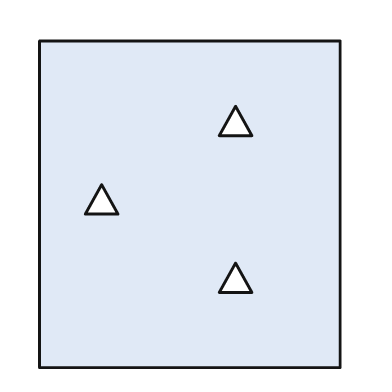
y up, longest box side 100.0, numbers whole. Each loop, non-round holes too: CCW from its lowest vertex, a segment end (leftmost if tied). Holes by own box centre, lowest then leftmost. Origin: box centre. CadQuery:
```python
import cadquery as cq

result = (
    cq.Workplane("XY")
    .moveTo(-46.0, -50.0)
    .lineTo(46.0, -50.0)
    .lineTo(46.0, 50.0)
    .lineTo(-46.0, 50.0)
    .close()
    .moveTo(9.0, -27.0)
    .lineTo(19.0, -27.0)
    .lineTo(14.0, -18.0)
    .close()
    .moveTo(-32.0, -3.0)
    .lineTo(-22.0, -3.0)
    .lineTo(-27.0, 6.0)
    .close()
    .moveTo(9.0, 21.0)
    .lineTo(19.0, 21.0)
    .lineTo(14.0, 30.0)
    .close()
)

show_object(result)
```